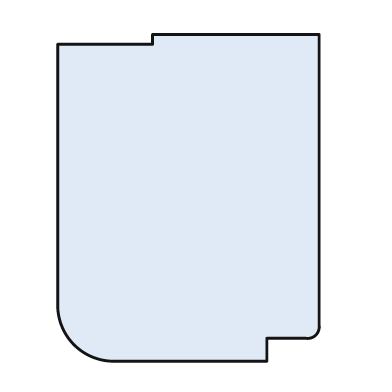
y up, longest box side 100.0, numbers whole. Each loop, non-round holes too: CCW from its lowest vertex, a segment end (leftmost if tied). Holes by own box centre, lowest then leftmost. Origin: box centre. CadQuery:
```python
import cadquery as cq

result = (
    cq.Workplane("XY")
    .moveTo(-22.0, -50.0)
    .lineTo(24.0, -50.0)
    .lineTo(24.0, -43.0)
    .lineTo(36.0, -43.0)
    .threePointArc((39.0, -42.0), (40.0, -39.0))
    .lineTo(40.0, 50.0)
    .lineTo(-11.0, 50.0)
    .lineTo(-11.0, 47.0)
    .lineTo(-40.0, 47.0)
    .lineTo(-40.0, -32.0)
    .threePointArc((-35.0, -45.0), (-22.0, -50.0))
    .close()
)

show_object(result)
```